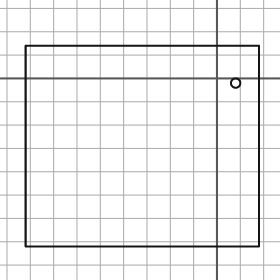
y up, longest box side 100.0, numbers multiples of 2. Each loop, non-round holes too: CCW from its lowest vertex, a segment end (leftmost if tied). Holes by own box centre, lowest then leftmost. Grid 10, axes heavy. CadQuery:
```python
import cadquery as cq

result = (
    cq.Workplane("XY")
    .moveTo(-82.0, -72.0)
    .lineTo(18.0, -72.0)
    .lineTo(18.0, 14.0)
    .lineTo(-82.0, 14.0)
    .close()
    .moveTo(8.0, -2.0)
    .circle(2.0)
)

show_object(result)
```